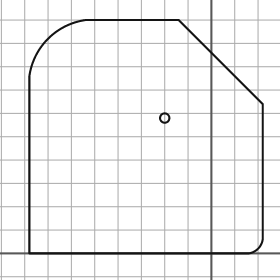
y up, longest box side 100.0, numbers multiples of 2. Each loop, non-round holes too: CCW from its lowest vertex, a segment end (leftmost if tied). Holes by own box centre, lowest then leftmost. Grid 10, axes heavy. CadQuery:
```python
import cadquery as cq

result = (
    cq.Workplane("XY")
    .moveTo(-78.0, 0.0)
    .lineTo(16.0, 0.0)
    .threePointArc((20.0, 2.0), (22.0, 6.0))
    .lineTo(22.0, 64.0)
    .lineTo(-14.0, 100.0)
    .lineTo(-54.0, 100.0)
    .threePointArc((-70.0, 92.0), (-78.0, 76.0))
    .close()
    .moveTo(-20.0, 58.0)
    .circle(2.0)
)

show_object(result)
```